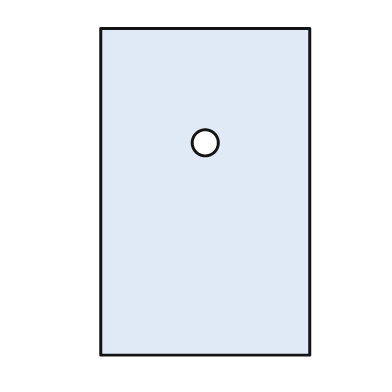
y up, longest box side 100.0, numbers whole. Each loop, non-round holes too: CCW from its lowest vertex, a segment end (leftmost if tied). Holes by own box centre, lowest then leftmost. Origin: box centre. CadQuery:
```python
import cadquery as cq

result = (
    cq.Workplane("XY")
    .moveTo(-32.0, -50.0)
    .lineTo(32.0, -50.0)
    .lineTo(32.0, 50.0)
    .lineTo(-32.0, 50.0)
    .close()
    .moveTo(0.0, 15.0)
    .circle(4.0)
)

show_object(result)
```